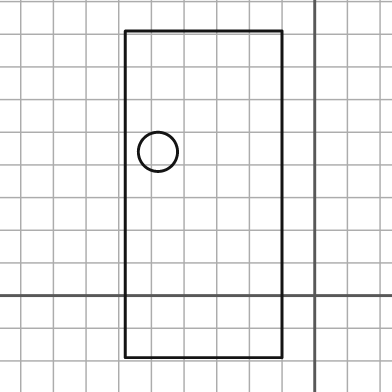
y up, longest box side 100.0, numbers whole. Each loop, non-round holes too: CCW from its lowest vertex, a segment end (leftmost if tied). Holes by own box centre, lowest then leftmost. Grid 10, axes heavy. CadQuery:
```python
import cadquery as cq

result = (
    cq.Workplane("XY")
    .moveTo(-58.0, -19.0)
    .lineTo(-10.0, -19.0)
    .lineTo(-10.0, 81.0)
    .lineTo(-58.0, 81.0)
    .close()
    .moveTo(-48.0, 44.0)
    .circle(6.0)
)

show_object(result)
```